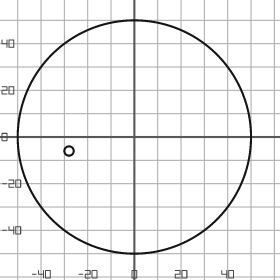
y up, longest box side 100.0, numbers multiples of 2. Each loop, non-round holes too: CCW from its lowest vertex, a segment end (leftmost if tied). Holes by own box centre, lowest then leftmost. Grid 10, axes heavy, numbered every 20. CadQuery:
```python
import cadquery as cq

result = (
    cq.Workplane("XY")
    .moveTo(0.0, 0.0)
    .circle(50.0)
    .moveTo(-28.0, -6.0)
    .circle(2.0)
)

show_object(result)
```